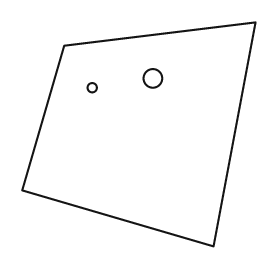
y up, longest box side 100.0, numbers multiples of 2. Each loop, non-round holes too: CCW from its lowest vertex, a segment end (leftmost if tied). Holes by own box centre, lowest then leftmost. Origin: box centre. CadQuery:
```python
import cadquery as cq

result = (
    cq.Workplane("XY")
    .moveTo(32.0, -48.0)
    .lineTo(50.0, 48.0)
    .lineTo(-32.0, 38.0)
    .lineTo(-50.0, -24.0)
    .close()
    .moveTo(-20.0, 20.0)
    .circle(2.0)
    .moveTo(6.0, 24.0)
    .circle(4.0)
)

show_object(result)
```